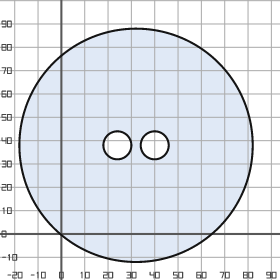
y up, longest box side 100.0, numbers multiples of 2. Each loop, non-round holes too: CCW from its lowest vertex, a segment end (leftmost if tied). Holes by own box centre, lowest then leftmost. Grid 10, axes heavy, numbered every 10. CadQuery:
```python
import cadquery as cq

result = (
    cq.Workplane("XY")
    .moveTo(32.0, 38.0)
    .circle(50.0)
    .moveTo(24.0, 38.0)
    .circle(6.0)
    .moveTo(40.0, 38.0)
    .circle(6.0)
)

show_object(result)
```